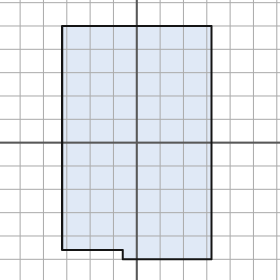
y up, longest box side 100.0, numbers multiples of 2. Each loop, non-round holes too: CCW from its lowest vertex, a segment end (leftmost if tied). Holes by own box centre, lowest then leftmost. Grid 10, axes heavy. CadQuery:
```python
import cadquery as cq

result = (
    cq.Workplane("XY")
    .moveTo(-6.0, -50.0)
    .lineTo(32.0, -50.0)
    .lineTo(32.0, 50.0)
    .lineTo(-32.0, 50.0)
    .lineTo(-32.0, -46.0)
    .lineTo(-6.0, -46.0)
    .close()
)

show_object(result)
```